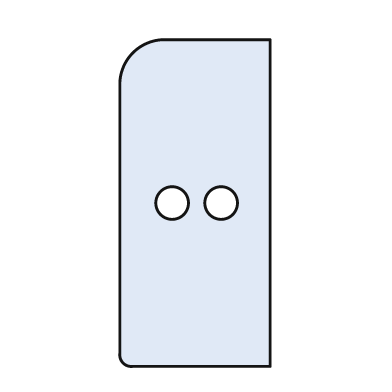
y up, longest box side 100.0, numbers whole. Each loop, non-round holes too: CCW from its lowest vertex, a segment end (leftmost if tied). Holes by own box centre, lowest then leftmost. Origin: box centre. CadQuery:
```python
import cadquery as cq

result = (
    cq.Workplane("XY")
    .moveTo(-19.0, -50.0)
    .lineTo(23.0, -50.0)
    .lineTo(23.0, 50.0)
    .lineTo(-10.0, 50.0)
    .threePointArc((-19.0, 46.0), (-23.0, 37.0))
    .lineTo(-23.0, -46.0)
    .threePointArc((-22.0, -49.0), (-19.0, -50.0))
    .close()
    .moveTo(-7.0, 0.0)
    .circle(5.0)
    .moveTo(8.0, 0.0)
    .circle(5.0)
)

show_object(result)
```